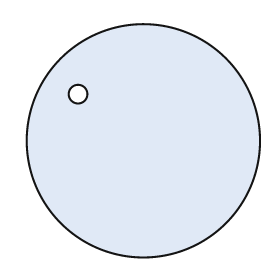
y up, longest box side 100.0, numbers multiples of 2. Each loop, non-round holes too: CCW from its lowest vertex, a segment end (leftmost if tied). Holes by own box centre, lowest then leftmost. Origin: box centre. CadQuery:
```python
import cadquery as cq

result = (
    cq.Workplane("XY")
    .moveTo(0.0, 0.0)
    .circle(50.0)
    .moveTo(-28.0, 20.0)
    .circle(4.0)
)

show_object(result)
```